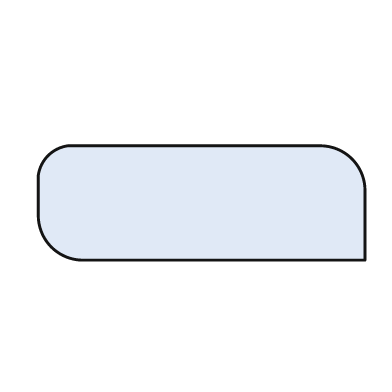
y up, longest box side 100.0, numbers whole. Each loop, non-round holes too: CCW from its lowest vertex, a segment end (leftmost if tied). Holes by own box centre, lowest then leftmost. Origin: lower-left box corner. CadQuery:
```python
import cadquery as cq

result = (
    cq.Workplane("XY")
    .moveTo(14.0, 0.0)
    .lineTo(100.0, 0.0)
    .lineTo(100.0, 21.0)
    .threePointArc((96.0, 31.0), (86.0, 35.0))
    .lineTo(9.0, 35.0)
    .threePointArc((3.0, 32.0), (0.0, 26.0))
    .lineTo(0.0, 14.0)
    .threePointArc((4.0, 4.0), (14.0, 0.0))
    .close()
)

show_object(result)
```